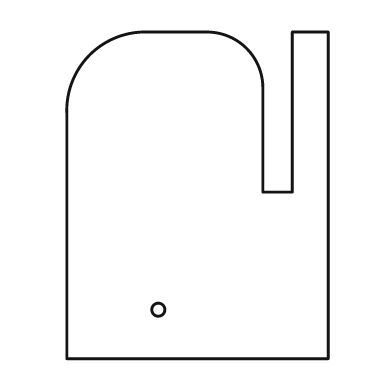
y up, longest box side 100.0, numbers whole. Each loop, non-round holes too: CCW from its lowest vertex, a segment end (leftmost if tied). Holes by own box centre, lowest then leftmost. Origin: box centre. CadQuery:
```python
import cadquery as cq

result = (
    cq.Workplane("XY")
    .moveTo(-40.0, -50.0)
    .lineTo(40.0, -50.0)
    .lineTo(40.0, 50.0)
    .lineTo(29.0, 50.0)
    .lineTo(29.0, 1.0)
    .lineTo(20.0, 1.0)
    .lineTo(20.0, 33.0)
    .threePointArc((15.0, 45.0), (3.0, 50.0))
    .lineTo(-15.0, 50.0)
    .threePointArc((-33.0, 43.0), (-40.0, 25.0))
    .close()
    .moveTo(-12.0, -35.0)
    .circle(2.0)
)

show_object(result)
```